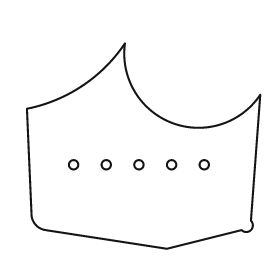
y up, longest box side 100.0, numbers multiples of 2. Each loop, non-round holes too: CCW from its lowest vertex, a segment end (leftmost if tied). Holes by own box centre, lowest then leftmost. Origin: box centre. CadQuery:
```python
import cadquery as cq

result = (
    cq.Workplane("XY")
    .moveTo(10.0, -44.0)
    .lineTo(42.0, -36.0)
    .threePointArc((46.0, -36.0), (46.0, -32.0))
    .lineTo(50.0, 22.0)
    .threePointArc((12.0, 10.0), (-8.0, 44.0))
    .threePointArc((-26.0, 26.0), (-50.0, 16.0))
    .lineTo(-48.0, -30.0)
    .threePointArc((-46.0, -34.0), (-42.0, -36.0))
    .close()
    .moveTo(-30.0, -8.0)
    .circle(2.0)
    .moveTo(-16.0, -8.0)
    .circle(2.0)
    .moveTo(-2.0, -8.0)
    .circle(2.0)
    .moveTo(12.0, -8.0)
    .circle(2.0)
    .moveTo(26.0, -8.0)
    .circle(2.0)
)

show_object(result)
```